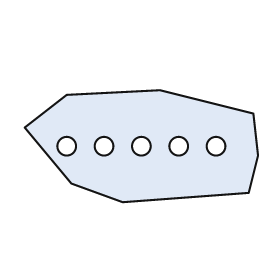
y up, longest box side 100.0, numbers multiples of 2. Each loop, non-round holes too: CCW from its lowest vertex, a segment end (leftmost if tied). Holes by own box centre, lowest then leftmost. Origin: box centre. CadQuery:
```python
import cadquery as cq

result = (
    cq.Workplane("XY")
    .moveTo(-8.0, -24.0)
    .lineTo(46.0, -20.0)
    .lineTo(50.0, -4.0)
    .lineTo(48.0, 14.0)
    .lineTo(8.0, 24.0)
    .lineTo(-32.0, 22.0)
    .lineTo(-50.0, 8.0)
    .lineTo(-30.0, -16.0)
    .close()
    .moveTo(-32.0, 0.0)
    .circle(4.0)
    .moveTo(-16.0, 0.0)
    .circle(4.0)
    .moveTo(0.0, 0.0)
    .circle(4.0)
    .moveTo(16.0, 0.0)
    .circle(4.0)
    .moveTo(32.0, 0.0)
    .circle(4.0)
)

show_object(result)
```